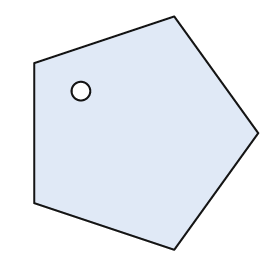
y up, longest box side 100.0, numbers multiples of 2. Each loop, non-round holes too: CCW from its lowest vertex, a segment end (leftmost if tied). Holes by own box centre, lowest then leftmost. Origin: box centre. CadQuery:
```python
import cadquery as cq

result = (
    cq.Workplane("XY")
    .moveTo(12.0, -50.0)
    .lineTo(48.0, 0.0)
    .lineTo(12.0, 50.0)
    .lineTo(-48.0, 30.0)
    .lineTo(-48.0, -30.0)
    .close()
    .moveTo(-28.0, 18.0)
    .circle(4.0)
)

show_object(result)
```